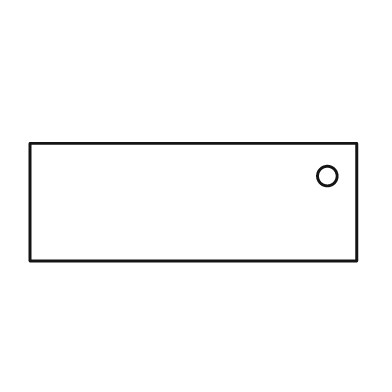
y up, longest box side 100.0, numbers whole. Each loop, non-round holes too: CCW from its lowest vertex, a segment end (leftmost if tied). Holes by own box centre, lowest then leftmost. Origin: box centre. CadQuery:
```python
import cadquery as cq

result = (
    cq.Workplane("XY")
    .moveTo(-50.0, -18.0)
    .lineTo(50.0, -18.0)
    .lineTo(50.0, 18.0)
    .lineTo(-50.0, 18.0)
    .close()
    .moveTo(41.0, 8.0)
    .circle(3.0)
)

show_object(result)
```